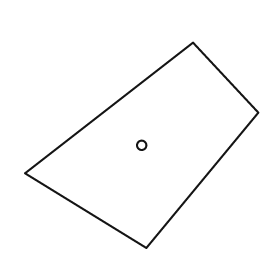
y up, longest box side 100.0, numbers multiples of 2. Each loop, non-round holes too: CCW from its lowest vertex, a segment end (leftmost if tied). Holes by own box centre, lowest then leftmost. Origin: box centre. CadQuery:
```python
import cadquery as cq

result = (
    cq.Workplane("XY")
    .moveTo(2.0, -44.0)
    .lineTo(50.0, 14.0)
    .lineTo(22.0, 44.0)
    .lineTo(-50.0, -12.0)
    .close()
    .moveTo(0.0, 0.0)
    .circle(2.0)
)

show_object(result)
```